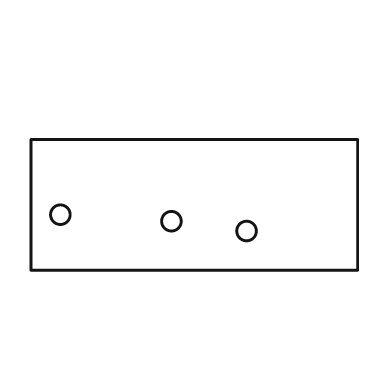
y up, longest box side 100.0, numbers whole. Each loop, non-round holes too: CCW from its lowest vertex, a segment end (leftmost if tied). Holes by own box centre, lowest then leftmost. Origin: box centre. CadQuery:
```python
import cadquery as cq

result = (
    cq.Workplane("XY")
    .moveTo(-50.0, -20.0)
    .lineTo(50.0, -20.0)
    .lineTo(50.0, 20.0)
    .lineTo(-50.0, 20.0)
    .close()
    .moveTo(16.0, -8.0)
    .circle(3.0)
    .moveTo(-7.0, -5.0)
    .circle(3.0)
    .moveTo(-41.0, -3.0)
    .circle(3.0)
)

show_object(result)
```